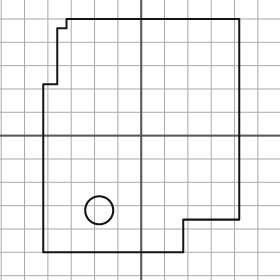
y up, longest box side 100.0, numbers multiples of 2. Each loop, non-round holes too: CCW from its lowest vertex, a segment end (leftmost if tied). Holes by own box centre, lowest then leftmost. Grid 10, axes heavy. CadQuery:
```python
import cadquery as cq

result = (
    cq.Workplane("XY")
    .moveTo(-42.0, -50.0)
    .lineTo(18.0, -50.0)
    .lineTo(18.0, -36.0)
    .lineTo(42.0, -36.0)
    .lineTo(42.0, 50.0)
    .lineTo(-32.0, 50.0)
    .lineTo(-32.0, 46.0)
    .lineTo(-36.0, 46.0)
    .lineTo(-36.0, 22.0)
    .lineTo(-42.0, 22.0)
    .close()
    .moveTo(-18.0, -32.0)
    .circle(6.0)
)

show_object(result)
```